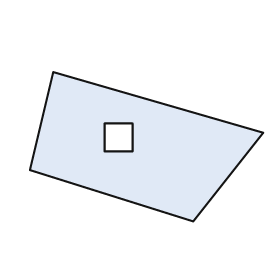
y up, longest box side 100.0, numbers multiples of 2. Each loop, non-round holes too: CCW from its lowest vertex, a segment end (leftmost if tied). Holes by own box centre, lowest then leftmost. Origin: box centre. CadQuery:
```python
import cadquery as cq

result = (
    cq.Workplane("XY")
    .moveTo(20.0, -32.0)
    .lineTo(50.0, 6.0)
    .lineTo(-40.0, 32.0)
    .lineTo(-50.0, -10.0)
    .close()
    .moveTo(-18.0, -2.0)
    .lineTo(-6.0, -2.0)
    .lineTo(-6.0, 10.0)
    .lineTo(-18.0, 10.0)
    .close()
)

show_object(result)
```